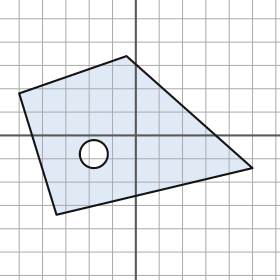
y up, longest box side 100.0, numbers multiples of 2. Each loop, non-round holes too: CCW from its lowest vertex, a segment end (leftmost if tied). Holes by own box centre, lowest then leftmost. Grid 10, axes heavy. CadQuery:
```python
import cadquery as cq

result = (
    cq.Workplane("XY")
    .moveTo(-34.0, -34.0)
    .lineTo(50.0, -14.0)
    .lineTo(-4.0, 34.0)
    .lineTo(-50.0, 18.0)
    .close()
    .moveTo(-18.0, -8.0)
    .circle(6.0)
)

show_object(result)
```